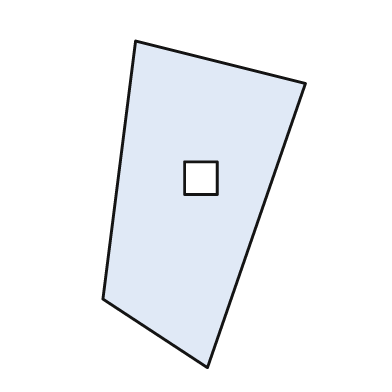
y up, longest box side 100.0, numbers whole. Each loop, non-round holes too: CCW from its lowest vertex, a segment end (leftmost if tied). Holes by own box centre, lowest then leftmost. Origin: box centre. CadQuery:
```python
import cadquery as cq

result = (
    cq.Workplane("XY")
    .moveTo(1.0, -50.0)
    .lineTo(31.0, 37.0)
    .lineTo(-21.0, 50.0)
    .lineTo(-31.0, -29.0)
    .close()
    .moveTo(-6.0, 3.0)
    .lineTo(4.0, 3.0)
    .lineTo(4.0, 13.0)
    .lineTo(-6.0, 13.0)
    .close()
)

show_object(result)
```